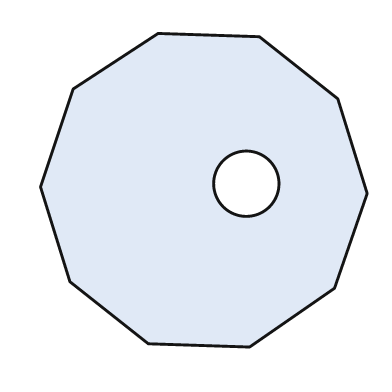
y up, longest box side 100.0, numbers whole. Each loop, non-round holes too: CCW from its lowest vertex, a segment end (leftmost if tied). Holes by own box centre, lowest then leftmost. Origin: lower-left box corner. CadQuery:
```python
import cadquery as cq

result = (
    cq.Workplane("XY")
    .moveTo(64.0, 0.0)
    .lineTo(90.0, 18.0)
    .lineTo(100.0, 47.0)
    .lineTo(91.0, 76.0)
    .lineTo(67.0, 95.0)
    .lineTo(36.0, 96.0)
    .lineTo(10.0, 79.0)
    .lineTo(0.0, 49.0)
    .lineTo(9.0, 20.0)
    .lineTo(33.0, 1.0)
    .close()
    .moveTo(63.0, 50.0)
    .circle(10.0)
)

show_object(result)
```